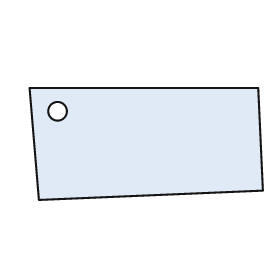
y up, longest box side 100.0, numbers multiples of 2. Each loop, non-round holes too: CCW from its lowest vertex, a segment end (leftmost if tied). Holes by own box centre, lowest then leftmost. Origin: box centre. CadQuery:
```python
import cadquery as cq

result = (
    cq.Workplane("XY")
    .moveTo(-46.0, -24.0)
    .lineTo(50.0, -20.0)
    .lineTo(48.0, 24.0)
    .lineTo(-50.0, 24.0)
    .close()
    .moveTo(-38.0, 14.0)
    .circle(4.0)
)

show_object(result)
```